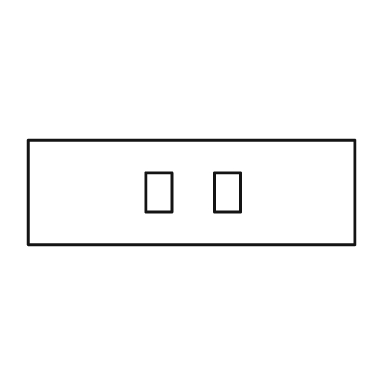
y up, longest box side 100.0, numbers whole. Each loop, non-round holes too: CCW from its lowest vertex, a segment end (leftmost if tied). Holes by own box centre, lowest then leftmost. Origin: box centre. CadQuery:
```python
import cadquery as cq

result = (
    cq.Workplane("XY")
    .moveTo(-50.0, -16.0)
    .lineTo(50.0, -16.0)
    .lineTo(50.0, 16.0)
    .lineTo(-50.0, 16.0)
    .close()
    .moveTo(-14.0, -6.0)
    .lineTo(-6.0, -6.0)
    .lineTo(-6.0, 6.0)
    .lineTo(-14.0, 6.0)
    .close()
    .moveTo(7.0, -6.0)
    .lineTo(15.0, -6.0)
    .lineTo(15.0, 6.0)
    .lineTo(7.0, 6.0)
    .close()
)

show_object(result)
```